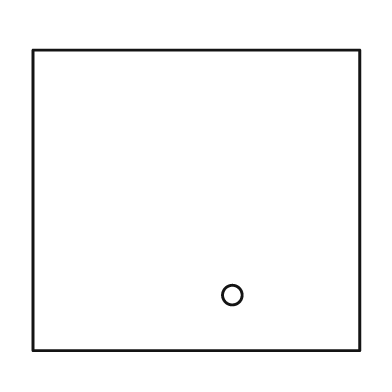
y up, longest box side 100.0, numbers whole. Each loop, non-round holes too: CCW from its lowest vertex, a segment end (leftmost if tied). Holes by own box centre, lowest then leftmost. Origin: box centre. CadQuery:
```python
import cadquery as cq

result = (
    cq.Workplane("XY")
    .moveTo(-50.0, -46.0)
    .lineTo(50.0, -46.0)
    .lineTo(50.0, 46.0)
    .lineTo(-50.0, 46.0)
    .close()
    .moveTo(11.0, -29.0)
    .circle(3.0)
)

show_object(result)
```